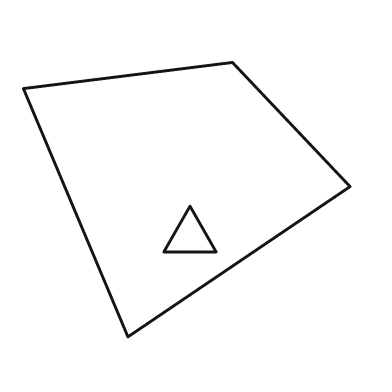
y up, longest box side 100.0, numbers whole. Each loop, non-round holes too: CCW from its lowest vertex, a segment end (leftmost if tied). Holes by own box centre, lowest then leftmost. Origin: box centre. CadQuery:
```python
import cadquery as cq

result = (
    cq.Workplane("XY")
    .moveTo(-18.0, -42.0)
    .lineTo(50.0, 4.0)
    .lineTo(14.0, 42.0)
    .lineTo(-50.0, 34.0)
    .close()
    .moveTo(-7.0, -16.0)
    .lineTo(9.0, -16.0)
    .lineTo(1.0, -2.0)
    .close()
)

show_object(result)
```